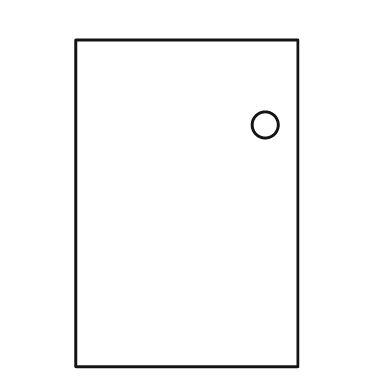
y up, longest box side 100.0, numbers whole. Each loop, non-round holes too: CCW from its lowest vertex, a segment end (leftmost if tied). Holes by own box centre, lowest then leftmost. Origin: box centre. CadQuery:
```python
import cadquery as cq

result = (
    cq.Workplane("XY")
    .moveTo(-34.0, -50.0)
    .lineTo(34.0, -50.0)
    .lineTo(34.0, 50.0)
    .lineTo(-34.0, 50.0)
    .close()
    .moveTo(24.0, 24.0)
    .circle(4.0)
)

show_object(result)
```